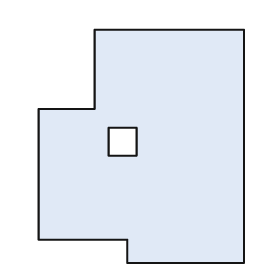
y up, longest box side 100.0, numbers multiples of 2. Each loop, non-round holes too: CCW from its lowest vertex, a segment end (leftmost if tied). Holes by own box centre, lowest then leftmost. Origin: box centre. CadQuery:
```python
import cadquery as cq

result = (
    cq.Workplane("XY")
    .moveTo(-6.0, -50.0)
    .lineTo(44.0, -50.0)
    .lineTo(44.0, 50.0)
    .lineTo(-20.0, 50.0)
    .lineTo(-20.0, 16.0)
    .lineTo(-44.0, 16.0)
    .lineTo(-44.0, -40.0)
    .lineTo(-6.0, -40.0)
    .close()
    .moveTo(-14.0, -4.0)
    .lineTo(-2.0, -4.0)
    .lineTo(-2.0, 8.0)
    .lineTo(-14.0, 8.0)
    .close()
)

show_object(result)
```